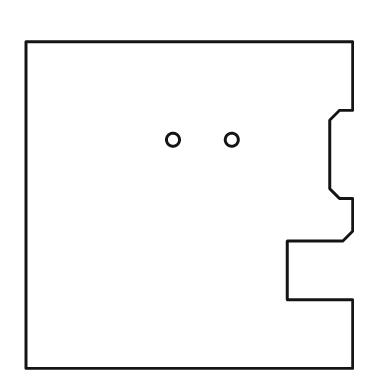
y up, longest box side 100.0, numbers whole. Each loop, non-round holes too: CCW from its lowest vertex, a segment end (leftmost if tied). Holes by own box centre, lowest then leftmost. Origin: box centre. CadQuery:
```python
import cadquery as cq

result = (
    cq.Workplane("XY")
    .moveTo(-50.0, -50.0)
    .lineTo(50.0, -50.0)
    .lineTo(50.0, -29.0)
    .lineTo(30.0, -29.0)
    .lineTo(30.0, -11.0)
    .lineTo(47.0, -11.0)
    .lineTo(50.0, -8.0)
    .lineTo(50.0, 2.0)
    .lineTo(46.0, 2.0)
    .lineTo(43.0, 5.0)
    .lineTo(43.0, 26.0)
    .lineTo(46.0, 29.0)
    .lineTo(50.0, 29.0)
    .lineTo(50.0, 50.0)
    .lineTo(-50.0, 50.0)
    .close()
    .moveTo(-5.0, 20.0)
    .circle(2.0)
    .moveTo(13.0, 20.0)
    .circle(2.0)
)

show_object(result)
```